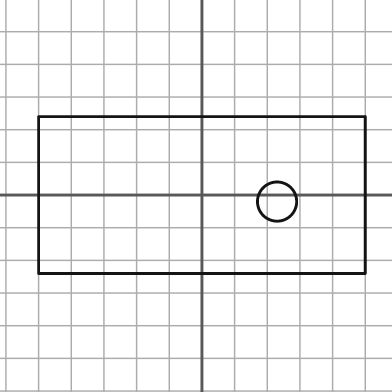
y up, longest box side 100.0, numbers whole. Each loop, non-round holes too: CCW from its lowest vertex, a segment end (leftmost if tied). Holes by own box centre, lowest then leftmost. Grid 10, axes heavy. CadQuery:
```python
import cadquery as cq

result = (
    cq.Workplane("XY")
    .moveTo(-50.0, -24.0)
    .lineTo(50.0, -24.0)
    .lineTo(50.0, 24.0)
    .lineTo(-50.0, 24.0)
    .close()
    .moveTo(23.0, -2.0)
    .circle(6.0)
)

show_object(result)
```